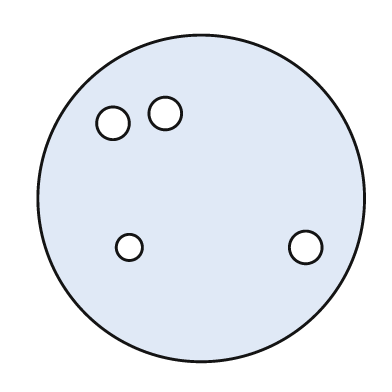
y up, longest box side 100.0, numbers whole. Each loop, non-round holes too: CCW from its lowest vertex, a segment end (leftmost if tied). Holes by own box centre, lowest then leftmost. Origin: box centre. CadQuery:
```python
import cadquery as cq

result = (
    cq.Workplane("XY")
    .moveTo(0.0, 0.0)
    .circle(50.0)
    .moveTo(-22.0, -15.0)
    .circle(4.0)
    .moveTo(32.0, -15.0)
    .circle(5.0)
    .moveTo(-27.0, 23.0)
    .circle(5.0)
    .moveTo(-11.0, 26.0)
    .circle(5.0)
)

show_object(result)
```